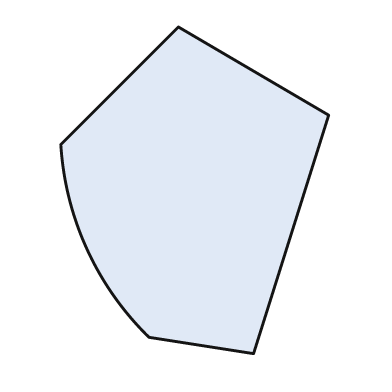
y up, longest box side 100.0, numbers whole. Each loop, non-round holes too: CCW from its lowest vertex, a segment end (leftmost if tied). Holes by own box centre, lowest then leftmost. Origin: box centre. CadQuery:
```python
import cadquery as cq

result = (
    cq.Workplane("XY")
    .moveTo(18.0, -50.0)
    .lineTo(41.0, 23.0)
    .lineTo(-5.0, 50.0)
    .lineTo(-41.0, 14.0)
    .threePointArc((-33.0, -18.0), (-14.0, -45.0))
    .close()
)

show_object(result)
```